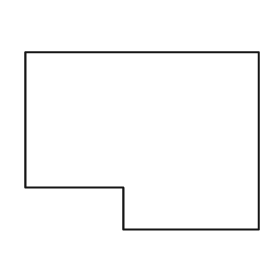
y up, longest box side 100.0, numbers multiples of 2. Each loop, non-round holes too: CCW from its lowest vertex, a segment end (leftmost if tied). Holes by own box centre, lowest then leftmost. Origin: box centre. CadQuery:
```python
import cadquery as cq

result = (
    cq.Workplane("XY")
    .moveTo(-8.0, -38.0)
    .lineTo(50.0, -38.0)
    .lineTo(50.0, 38.0)
    .lineTo(-50.0, 38.0)
    .lineTo(-50.0, -20.0)
    .lineTo(-8.0, -20.0)
    .close()
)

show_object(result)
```